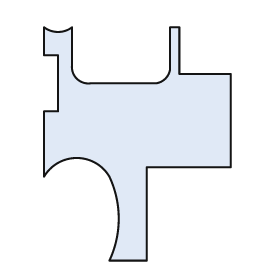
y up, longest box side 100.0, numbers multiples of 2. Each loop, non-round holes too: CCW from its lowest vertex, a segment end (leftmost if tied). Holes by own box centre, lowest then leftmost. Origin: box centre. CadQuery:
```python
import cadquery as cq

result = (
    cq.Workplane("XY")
    .moveTo(-12.0, -50.0)
    .lineTo(4.0, -50.0)
    .lineTo(4.0, -10.0)
    .lineTo(40.0, -10.0)
    .lineTo(40.0, 30.0)
    .lineTo(18.0, 30.0)
    .lineTo(18.0, 50.0)
    .lineTo(14.0, 50.0)
    .lineTo(14.0, 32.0)
    .threePointArc((12.0, 28.0), (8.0, 26.0))
    .lineTo(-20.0, 26.0)
    .threePointArc((-26.0, 28.0), (-28.0, 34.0))
    .lineTo(-28.0, 50.0)
    .threePointArc((-34.0, 48.0), (-40.0, 50.0))
    .lineTo(-40.0, 38.0)
    .lineTo(-34.0, 38.0)
    .lineTo(-34.0, 14.0)
    .lineTo(-40.0, 14.0)
    .lineTo(-40.0, -14.0)
    .threePointArc((-26.0, -6.0), (-12.0, -14.0))
    .threePointArc((-8.0, -32.0), (-12.0, -50.0))
    .close()
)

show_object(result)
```